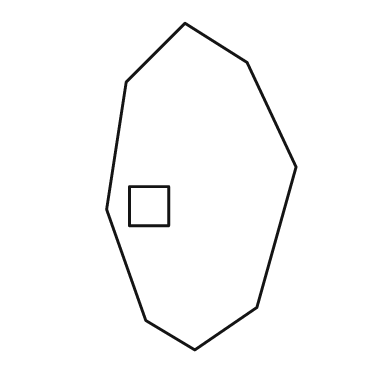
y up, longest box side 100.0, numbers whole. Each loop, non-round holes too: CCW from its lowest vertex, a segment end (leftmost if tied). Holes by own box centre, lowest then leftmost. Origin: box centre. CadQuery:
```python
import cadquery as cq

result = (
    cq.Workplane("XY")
    .moveTo(-2.0, -50.0)
    .lineTo(17.0, -37.0)
    .lineTo(29.0, 6.0)
    .lineTo(14.0, 38.0)
    .lineTo(-5.0, 50.0)
    .lineTo(-23.0, 32.0)
    .lineTo(-29.0, -7.0)
    .lineTo(-17.0, -41.0)
    .close()
    .moveTo(-22.0, -12.0)
    .lineTo(-10.0, -12.0)
    .lineTo(-10.0, 0.0)
    .lineTo(-22.0, 0.0)
    .close()
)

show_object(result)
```